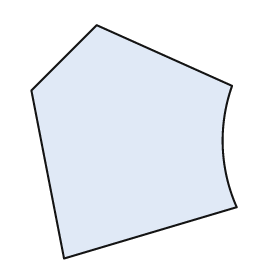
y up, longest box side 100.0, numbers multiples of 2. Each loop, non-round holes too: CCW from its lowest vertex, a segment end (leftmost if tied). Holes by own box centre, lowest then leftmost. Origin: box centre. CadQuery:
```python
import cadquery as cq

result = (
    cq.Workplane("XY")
    .moveTo(-30.0, -50.0)
    .lineTo(44.0, -28.0)
    .threePointArc((38.0, -2.0), (42.0, 24.0))
    .lineTo(-16.0, 50.0)
    .lineTo(-44.0, 22.0)
    .close()
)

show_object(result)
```